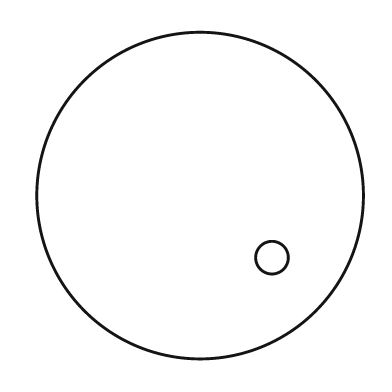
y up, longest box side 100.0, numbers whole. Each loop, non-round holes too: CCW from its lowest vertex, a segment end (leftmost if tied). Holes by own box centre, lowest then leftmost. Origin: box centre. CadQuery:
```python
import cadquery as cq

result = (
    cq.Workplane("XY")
    .moveTo(0.0, 0.0)
    .circle(50.0)
    .moveTo(22.0, -19.0)
    .circle(5.0)
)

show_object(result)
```